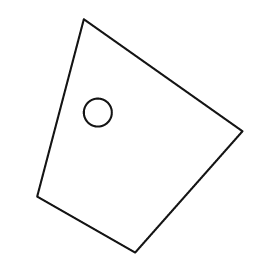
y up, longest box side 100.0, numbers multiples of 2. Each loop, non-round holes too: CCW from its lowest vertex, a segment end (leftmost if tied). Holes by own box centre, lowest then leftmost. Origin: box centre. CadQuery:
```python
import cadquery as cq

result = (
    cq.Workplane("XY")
    .moveTo(-2.0, -50.0)
    .lineTo(44.0, 2.0)
    .lineTo(-24.0, 50.0)
    .lineTo(-44.0, -26.0)
    .close()
    .moveTo(-18.0, 10.0)
    .circle(6.0)
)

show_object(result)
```